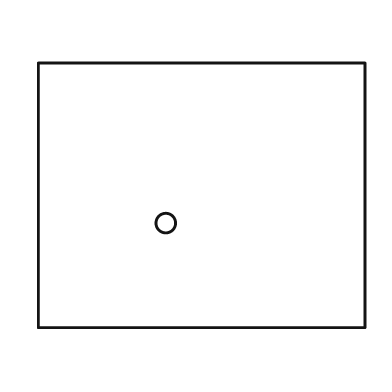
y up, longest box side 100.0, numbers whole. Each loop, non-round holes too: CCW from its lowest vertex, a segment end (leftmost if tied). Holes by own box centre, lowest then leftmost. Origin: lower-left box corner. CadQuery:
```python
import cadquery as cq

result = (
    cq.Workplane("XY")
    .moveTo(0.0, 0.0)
    .lineTo(100.0, 0.0)
    .lineTo(100.0, 81.0)
    .lineTo(0.0, 81.0)
    .close()
    .moveTo(39.0, 32.0)
    .circle(3.0)
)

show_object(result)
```